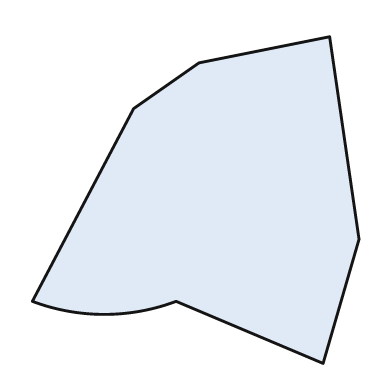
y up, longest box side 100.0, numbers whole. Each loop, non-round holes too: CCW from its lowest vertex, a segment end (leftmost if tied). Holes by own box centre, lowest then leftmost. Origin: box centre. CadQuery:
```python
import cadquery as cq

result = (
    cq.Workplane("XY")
    .moveTo(39.0, -50.0)
    .lineTo(50.0, -12.0)
    .lineTo(41.0, 50.0)
    .lineTo(1.0, 42.0)
    .lineTo(-19.0, 28.0)
    .lineTo(-50.0, -31.0)
    .threePointArc((-28.0, -35.0), (-6.0, -31.0))
    .close()
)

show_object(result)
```